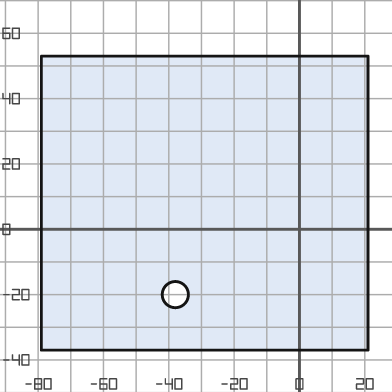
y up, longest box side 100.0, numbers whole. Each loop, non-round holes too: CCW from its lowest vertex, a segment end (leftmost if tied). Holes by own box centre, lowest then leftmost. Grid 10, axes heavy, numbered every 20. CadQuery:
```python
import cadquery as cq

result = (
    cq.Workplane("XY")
    .moveTo(-79.0, -37.0)
    .lineTo(21.0, -37.0)
    .lineTo(21.0, 53.0)
    .lineTo(-79.0, 53.0)
    .close()
    .moveTo(-38.0, -20.0)
    .circle(4.0)
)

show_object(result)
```